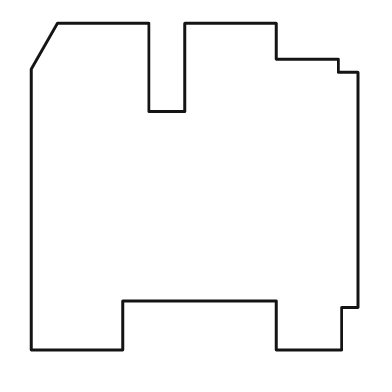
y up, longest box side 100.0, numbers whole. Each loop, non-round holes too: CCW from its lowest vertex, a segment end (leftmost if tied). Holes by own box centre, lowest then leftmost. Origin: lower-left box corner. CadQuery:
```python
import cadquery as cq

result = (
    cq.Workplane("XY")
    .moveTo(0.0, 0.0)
    .lineTo(28.0, 0.0)
    .lineTo(28.0, 15.0)
    .lineTo(75.0, 15.0)
    .lineTo(75.0, 0.0)
    .lineTo(95.0, 0.0)
    .lineTo(95.0, 13.0)
    .lineTo(100.0, 13.0)
    .lineTo(100.0, 85.0)
    .lineTo(94.0, 85.0)
    .lineTo(94.0, 89.0)
    .lineTo(75.0, 89.0)
    .lineTo(75.0, 100.0)
    .lineTo(47.0, 100.0)
    .lineTo(47.0, 73.0)
    .lineTo(36.0, 73.0)
    .lineTo(36.0, 100.0)
    .lineTo(8.0, 100.0)
    .lineTo(0.0, 86.0)
    .close()
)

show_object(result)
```